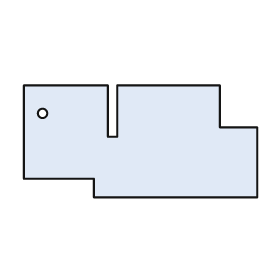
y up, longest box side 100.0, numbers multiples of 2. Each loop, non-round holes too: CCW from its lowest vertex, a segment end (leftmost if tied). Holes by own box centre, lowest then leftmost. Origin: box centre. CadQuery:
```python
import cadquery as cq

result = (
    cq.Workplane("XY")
    .moveTo(-20.0, -24.0)
    .lineTo(50.0, -24.0)
    .lineTo(50.0, 6.0)
    .lineTo(34.0, 6.0)
    .lineTo(34.0, 24.0)
    .lineTo(-10.0, 24.0)
    .lineTo(-10.0, 2.0)
    .lineTo(-14.0, 2.0)
    .lineTo(-14.0, 24.0)
    .lineTo(-50.0, 24.0)
    .lineTo(-50.0, -16.0)
    .lineTo(-20.0, -16.0)
    .close()
    .moveTo(-42.0, 12.0)
    .circle(2.0)
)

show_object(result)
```